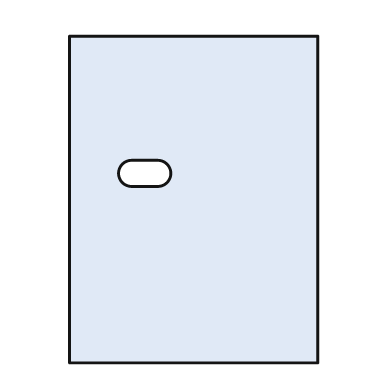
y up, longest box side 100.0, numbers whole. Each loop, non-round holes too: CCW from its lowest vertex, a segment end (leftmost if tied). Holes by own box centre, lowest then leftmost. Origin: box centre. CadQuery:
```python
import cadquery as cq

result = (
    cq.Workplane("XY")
    .moveTo(-38.0, -50.0)
    .lineTo(38.0, -50.0)
    .lineTo(38.0, 50.0)
    .lineTo(-38.0, 50.0)
    .close()
    .moveTo(-19.0, 4.0)
    .lineTo(-11.0, 4.0)
    .threePointArc((-7.0, 8.0), (-11.0, 12.0))
    .lineTo(-19.0, 12.0)
    .threePointArc((-23.0, 8.0), (-19.0, 4.0))
    .close()
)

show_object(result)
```